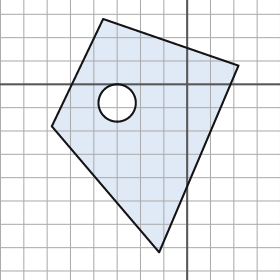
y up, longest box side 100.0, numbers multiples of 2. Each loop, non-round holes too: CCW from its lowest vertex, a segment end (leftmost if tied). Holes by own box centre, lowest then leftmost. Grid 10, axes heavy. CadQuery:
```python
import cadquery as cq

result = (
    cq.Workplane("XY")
    .moveTo(-12.0, -72.0)
    .lineTo(22.0, 8.0)
    .lineTo(-36.0, 28.0)
    .lineTo(-58.0, -18.0)
    .close()
    .moveTo(-30.0, -8.0)
    .circle(8.0)
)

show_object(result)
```